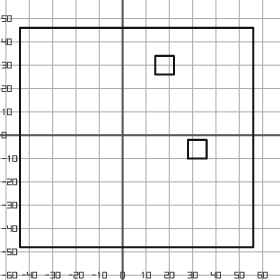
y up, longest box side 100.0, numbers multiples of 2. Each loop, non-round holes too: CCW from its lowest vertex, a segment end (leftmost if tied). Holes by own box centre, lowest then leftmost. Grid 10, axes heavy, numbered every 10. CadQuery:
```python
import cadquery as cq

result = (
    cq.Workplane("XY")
    .moveTo(-44.0, -48.0)
    .lineTo(56.0, -48.0)
    .lineTo(56.0, 46.0)
    .lineTo(-44.0, 46.0)
    .close()
    .moveTo(28.0, -10.0)
    .lineTo(36.0, -10.0)
    .lineTo(36.0, -2.0)
    .lineTo(28.0, -2.0)
    .close()
    .moveTo(14.0, 26.0)
    .lineTo(22.0, 26.0)
    .lineTo(22.0, 34.0)
    .lineTo(14.0, 34.0)
    .close()
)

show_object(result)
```